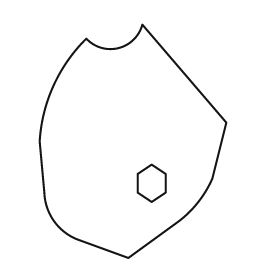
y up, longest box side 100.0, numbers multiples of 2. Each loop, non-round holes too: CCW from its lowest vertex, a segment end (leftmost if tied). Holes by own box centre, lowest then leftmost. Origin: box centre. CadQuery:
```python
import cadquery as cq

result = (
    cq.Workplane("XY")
    .moveTo(-2.0, -50.0)
    .lineTo(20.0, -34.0)
    .threePointArc((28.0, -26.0), (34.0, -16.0))
    .lineTo(40.0, 8.0)
    .lineTo(4.0, 50.0)
    .threePointArc((-6.0, 40.0), (-20.0, 44.0))
    .threePointArc((-34.0, 24.0), (-40.0, 0.0))
    .lineTo(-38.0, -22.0)
    .threePointArc((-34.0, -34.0), (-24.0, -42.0))
    .close()
    .moveTo(8.0, -26.0)
    .lineTo(14.0, -22.0)
    .lineTo(14.0, -14.0)
    .lineTo(8.0, -10.0)
    .lineTo(2.0, -14.0)
    .lineTo(2.0, -22.0)
    .close()
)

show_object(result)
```